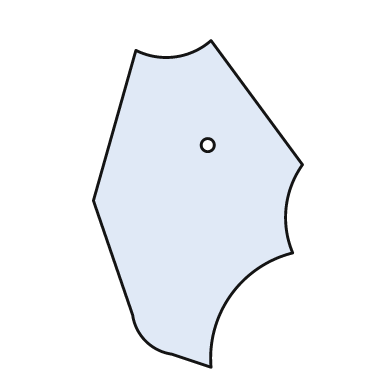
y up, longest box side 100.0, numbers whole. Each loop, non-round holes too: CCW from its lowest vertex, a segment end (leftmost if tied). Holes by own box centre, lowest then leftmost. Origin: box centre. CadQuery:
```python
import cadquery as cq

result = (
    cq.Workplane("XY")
    .moveTo(4.0, -50.0)
    .threePointArc((10.0, -28.0), (29.0, -15.0))
    .threePointArc((27.0, -1.0), (32.0, 12.0))
    .lineTo(4.0, 50.0)
    .threePointArc((-7.0, 45.0), (-19.0, 47.0))
    .lineTo(-32.0, 1.0)
    .lineTo(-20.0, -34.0)
    .threePointArc((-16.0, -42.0), (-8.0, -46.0))
    .close()
    .moveTo(3.0, 18.0)
    .circle(2.0)
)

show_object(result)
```